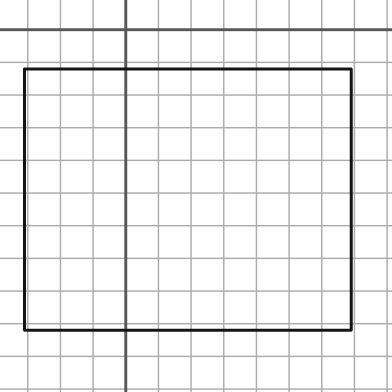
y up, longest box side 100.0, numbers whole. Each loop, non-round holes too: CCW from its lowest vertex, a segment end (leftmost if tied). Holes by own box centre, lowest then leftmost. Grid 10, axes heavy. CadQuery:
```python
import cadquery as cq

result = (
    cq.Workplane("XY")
    .moveTo(-31.0, -92.0)
    .lineTo(69.0, -92.0)
    .lineTo(69.0, -12.0)
    .lineTo(-31.0, -12.0)
    .close()
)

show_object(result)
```